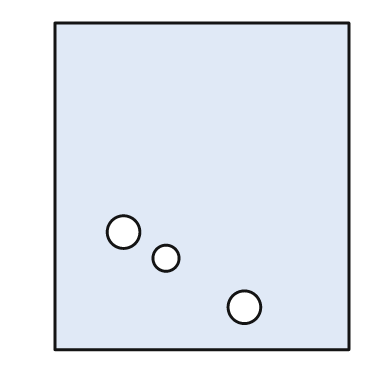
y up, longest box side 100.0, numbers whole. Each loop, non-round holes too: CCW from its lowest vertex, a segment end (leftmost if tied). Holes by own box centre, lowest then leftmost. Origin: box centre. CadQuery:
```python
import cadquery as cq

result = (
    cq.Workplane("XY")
    .moveTo(-45.0, -50.0)
    .lineTo(45.0, -50.0)
    .lineTo(45.0, 50.0)
    .lineTo(-45.0, 50.0)
    .close()
    .moveTo(13.0, -37.0)
    .circle(5.0)
    .moveTo(-11.0, -22.0)
    .circle(4.0)
    .moveTo(-24.0, -14.0)
    .circle(5.0)
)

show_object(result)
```